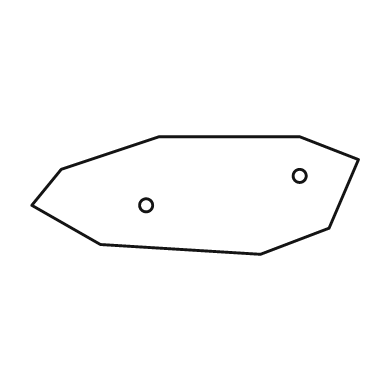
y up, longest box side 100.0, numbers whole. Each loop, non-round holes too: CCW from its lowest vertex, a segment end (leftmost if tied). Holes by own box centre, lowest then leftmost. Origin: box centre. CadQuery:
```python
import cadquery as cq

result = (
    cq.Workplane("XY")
    .moveTo(20.0, -18.0)
    .lineTo(41.0, -10.0)
    .lineTo(50.0, 11.0)
    .lineTo(32.0, 18.0)
    .lineTo(-11.0, 18.0)
    .lineTo(-41.0, 8.0)
    .lineTo(-50.0, -3.0)
    .lineTo(-29.0, -15.0)
    .close()
    .moveTo(-15.0, -3.0)
    .circle(2.0)
    .moveTo(32.0, 6.0)
    .circle(2.0)
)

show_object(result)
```